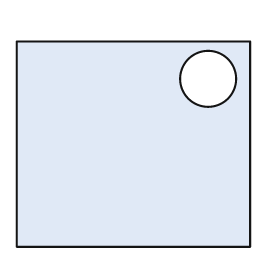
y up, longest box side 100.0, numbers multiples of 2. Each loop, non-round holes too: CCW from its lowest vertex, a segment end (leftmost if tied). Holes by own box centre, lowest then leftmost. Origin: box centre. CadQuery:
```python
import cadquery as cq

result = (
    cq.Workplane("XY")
    .moveTo(-50.0, -44.0)
    .lineTo(50.0, -44.0)
    .lineTo(50.0, 44.0)
    .lineTo(-50.0, 44.0)
    .close()
    .moveTo(32.0, 28.0)
    .circle(12.0)
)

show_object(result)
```